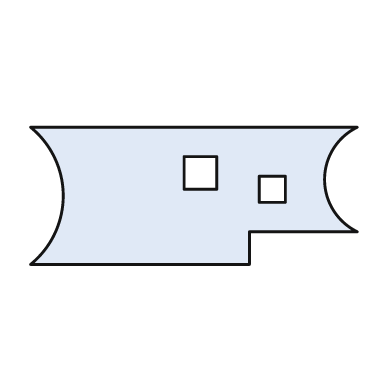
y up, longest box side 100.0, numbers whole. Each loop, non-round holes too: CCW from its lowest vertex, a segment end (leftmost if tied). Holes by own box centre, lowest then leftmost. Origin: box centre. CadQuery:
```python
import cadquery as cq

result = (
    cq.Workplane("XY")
    .moveTo(-50.0, -21.0)
    .lineTo(17.0, -21.0)
    .lineTo(17.0, -11.0)
    .lineTo(50.0, -11.0)
    .threePointArc((40.0, 5.0), (50.0, 21.0))
    .lineTo(-50.0, 21.0)
    .threePointArc((-40.0, 0.0), (-50.0, -21.0))
    .close()
    .moveTo(20.0, -2.0)
    .lineTo(28.0, -2.0)
    .lineTo(28.0, 6.0)
    .lineTo(20.0, 6.0)
    .close()
    .moveTo(-3.0, 2.0)
    .lineTo(7.0, 2.0)
    .lineTo(7.0, 12.0)
    .lineTo(-3.0, 12.0)
    .close()
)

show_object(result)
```